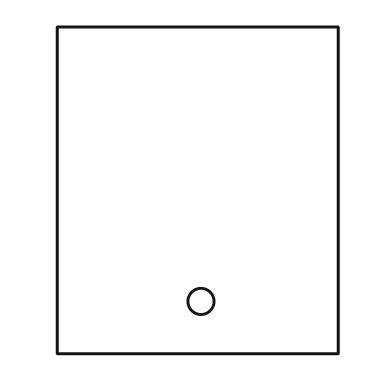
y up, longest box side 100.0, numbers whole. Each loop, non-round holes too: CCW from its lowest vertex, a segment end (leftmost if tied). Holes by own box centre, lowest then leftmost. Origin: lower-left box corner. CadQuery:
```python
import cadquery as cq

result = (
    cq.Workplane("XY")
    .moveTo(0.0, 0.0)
    .lineTo(86.0, 0.0)
    .lineTo(86.0, 100.0)
    .lineTo(0.0, 100.0)
    .close()
    .moveTo(44.0, 16.0)
    .circle(4.0)
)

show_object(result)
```